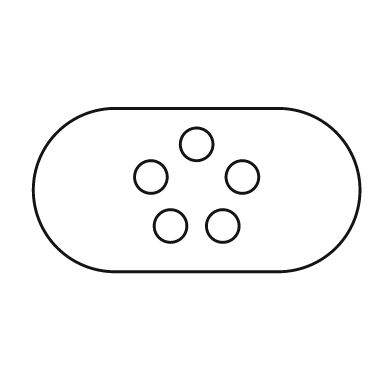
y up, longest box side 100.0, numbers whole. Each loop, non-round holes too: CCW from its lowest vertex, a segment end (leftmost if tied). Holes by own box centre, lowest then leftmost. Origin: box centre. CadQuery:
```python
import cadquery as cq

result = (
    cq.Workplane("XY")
    .moveTo(-25.0, -25.0)
    .lineTo(25.0, -25.0)
    .threePointArc((50.0, 0.0), (25.0, 25.0))
    .lineTo(-25.0, 25.0)
    .threePointArc((-50.0, 0.0), (-25.0, -25.0))
    .close()
    .moveTo(-8.0, -11.0)
    .circle(5.0)
    .moveTo(8.0, -11.0)
    .circle(5.0)
    .moveTo(-14.0, 4.0)
    .circle(5.0)
    .moveTo(14.0, 4.0)
    .circle(5.0)
    .moveTo(0.0, 14.0)
    .circle(5.0)
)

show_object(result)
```